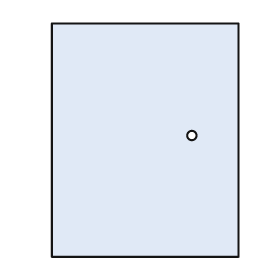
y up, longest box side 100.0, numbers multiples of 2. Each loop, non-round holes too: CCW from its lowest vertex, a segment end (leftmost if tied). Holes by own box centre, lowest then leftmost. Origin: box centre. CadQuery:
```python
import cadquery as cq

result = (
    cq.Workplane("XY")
    .moveTo(-40.0, -50.0)
    .lineTo(40.0, -50.0)
    .lineTo(40.0, 50.0)
    .lineTo(-40.0, 50.0)
    .close()
    .moveTo(20.0, 2.0)
    .circle(2.0)
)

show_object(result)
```